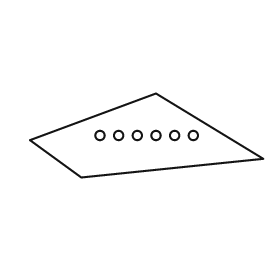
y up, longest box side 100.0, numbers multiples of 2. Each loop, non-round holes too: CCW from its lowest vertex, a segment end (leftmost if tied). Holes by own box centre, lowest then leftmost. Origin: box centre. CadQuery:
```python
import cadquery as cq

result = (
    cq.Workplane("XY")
    .moveTo(-28.0, -18.0)
    .lineTo(50.0, -10.0)
    .lineTo(4.0, 18.0)
    .lineTo(-50.0, -2.0)
    .close()
    .moveTo(-20.0, 0.0)
    .circle(2.0)
    .moveTo(-12.0, 0.0)
    .circle(2.0)
    .moveTo(-4.0, 0.0)
    .circle(2.0)
    .moveTo(4.0, 0.0)
    .circle(2.0)
    .moveTo(12.0, 0.0)
    .circle(2.0)
    .moveTo(20.0, 0.0)
    .circle(2.0)
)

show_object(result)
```